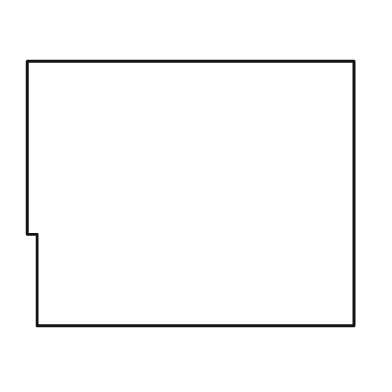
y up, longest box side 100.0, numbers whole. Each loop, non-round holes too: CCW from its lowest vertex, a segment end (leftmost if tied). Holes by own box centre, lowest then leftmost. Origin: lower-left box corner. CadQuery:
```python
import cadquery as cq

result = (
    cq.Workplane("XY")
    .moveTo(3.0, 0.0)
    .lineTo(100.0, 0.0)
    .lineTo(100.0, 81.0)
    .lineTo(0.0, 81.0)
    .lineTo(0.0, 28.0)
    .lineTo(3.0, 28.0)
    .close()
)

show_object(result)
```